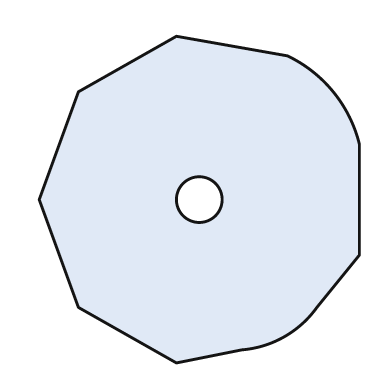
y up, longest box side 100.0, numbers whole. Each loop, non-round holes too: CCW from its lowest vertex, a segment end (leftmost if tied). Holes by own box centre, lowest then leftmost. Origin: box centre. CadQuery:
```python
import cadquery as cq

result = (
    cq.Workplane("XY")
    .moveTo(-7.0, -50.0)
    .lineTo(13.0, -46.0)
    .threePointArc((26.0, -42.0), (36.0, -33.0))
    .lineTo(49.0, -17.0)
    .lineTo(49.0, 17.0)
    .threePointArc((41.0, 33.0), (27.0, 44.0))
    .lineTo(-7.0, 50.0)
    .lineTo(-37.0, 33.0)
    .lineTo(-49.0, 0.0)
    .lineTo(-37.0, -33.0)
    .close()
    .moveTo(0.0, 0.0)
    .circle(7.0)
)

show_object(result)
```